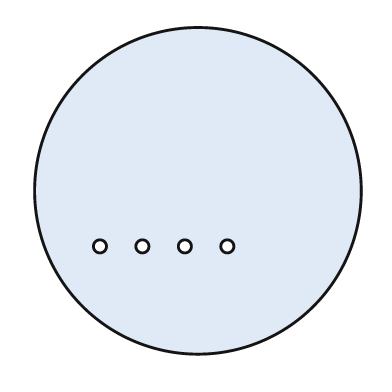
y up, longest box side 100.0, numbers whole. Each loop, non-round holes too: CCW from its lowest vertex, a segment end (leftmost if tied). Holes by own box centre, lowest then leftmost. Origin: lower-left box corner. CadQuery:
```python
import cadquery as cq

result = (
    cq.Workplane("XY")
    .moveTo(50.0, 50.0)
    .circle(50.0)
    .moveTo(20.0, 33.0)
    .circle(2.0)
    .moveTo(33.0, 33.0)
    .circle(2.0)
    .moveTo(46.0, 33.0)
    .circle(2.0)
    .moveTo(59.0, 33.0)
    .circle(2.0)
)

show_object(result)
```